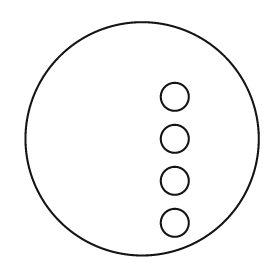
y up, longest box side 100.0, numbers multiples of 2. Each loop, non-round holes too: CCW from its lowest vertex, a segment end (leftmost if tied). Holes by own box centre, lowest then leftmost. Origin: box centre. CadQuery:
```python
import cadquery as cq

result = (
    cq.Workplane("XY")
    .moveTo(0.0, 0.0)
    .circle(50.0)
    .moveTo(14.0, -36.0)
    .circle(6.0)
    .moveTo(14.0, -18.0)
    .circle(6.0)
    .moveTo(14.0, 0.0)
    .circle(6.0)
    .moveTo(14.0, 18.0)
    .circle(6.0)
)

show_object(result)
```